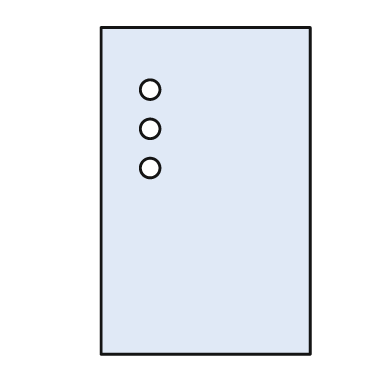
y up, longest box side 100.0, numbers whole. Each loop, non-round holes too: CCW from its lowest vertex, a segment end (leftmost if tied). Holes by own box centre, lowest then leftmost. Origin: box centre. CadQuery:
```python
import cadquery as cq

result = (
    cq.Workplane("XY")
    .moveTo(-32.0, -50.0)
    .lineTo(32.0, -50.0)
    .lineTo(32.0, 50.0)
    .lineTo(-32.0, 50.0)
    .close()
    .moveTo(-17.0, 7.0)
    .circle(3.0)
    .moveTo(-17.0, 19.0)
    .circle(3.0)
    .moveTo(-17.0, 31.0)
    .circle(3.0)
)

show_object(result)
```